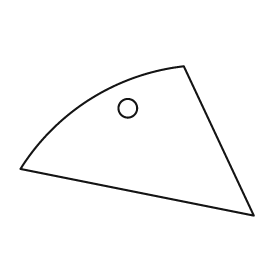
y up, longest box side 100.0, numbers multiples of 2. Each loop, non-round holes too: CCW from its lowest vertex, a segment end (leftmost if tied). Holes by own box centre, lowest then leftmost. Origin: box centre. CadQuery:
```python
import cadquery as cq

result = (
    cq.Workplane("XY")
    .moveTo(50.0, -32.0)
    .lineTo(20.0, 32.0)
    .threePointArc((-20.0, 18.0), (-50.0, -12.0))
    .close()
    .moveTo(-4.0, 14.0)
    .circle(4.0)
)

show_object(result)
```